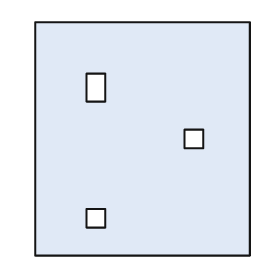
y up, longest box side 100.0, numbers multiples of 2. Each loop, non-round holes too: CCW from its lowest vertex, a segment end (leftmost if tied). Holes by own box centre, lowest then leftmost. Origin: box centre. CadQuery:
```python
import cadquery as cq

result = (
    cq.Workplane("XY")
    .moveTo(-46.0, -50.0)
    .lineTo(46.0, -50.0)
    .lineTo(46.0, 50.0)
    .lineTo(-46.0, 50.0)
    .close()
    .moveTo(-24.0, -38.0)
    .lineTo(-16.0, -38.0)
    .lineTo(-16.0, -30.0)
    .lineTo(-24.0, -30.0)
    .close()
    .moveTo(18.0, -4.0)
    .lineTo(26.0, -4.0)
    .lineTo(26.0, 4.0)
    .lineTo(18.0, 4.0)
    .close()
    .moveTo(-24.0, 16.0)
    .lineTo(-16.0, 16.0)
    .lineTo(-16.0, 28.0)
    .lineTo(-24.0, 28.0)
    .close()
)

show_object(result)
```